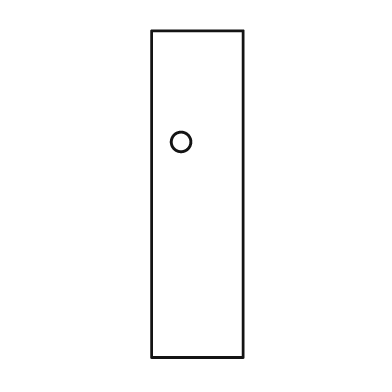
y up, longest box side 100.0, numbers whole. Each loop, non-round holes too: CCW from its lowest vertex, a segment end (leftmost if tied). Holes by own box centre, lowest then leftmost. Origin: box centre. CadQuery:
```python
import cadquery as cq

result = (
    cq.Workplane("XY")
    .moveTo(-14.0, -50.0)
    .lineTo(14.0, -50.0)
    .lineTo(14.0, 50.0)
    .lineTo(-14.0, 50.0)
    .close()
    .moveTo(-5.0, 16.0)
    .circle(3.0)
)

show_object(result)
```